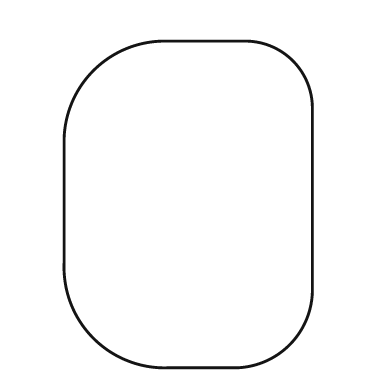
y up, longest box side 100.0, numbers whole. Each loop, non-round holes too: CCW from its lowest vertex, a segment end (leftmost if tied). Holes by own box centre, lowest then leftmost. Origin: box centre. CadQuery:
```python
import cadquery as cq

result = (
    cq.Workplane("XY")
    .moveTo(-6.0, -50.0)
    .lineTo(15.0, -50.0)
    .threePointArc((31.0, -43.0), (38.0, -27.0))
    .lineTo(38.0, 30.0)
    .threePointArc((32.0, 44.0), (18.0, 50.0))
    .lineTo(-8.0, 50.0)
    .threePointArc((-29.0, 41.0), (-38.0, 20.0))
    .lineTo(-38.0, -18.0)
    .threePointArc((-29.0, -41.0), (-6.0, -50.0))
    .close()
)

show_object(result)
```